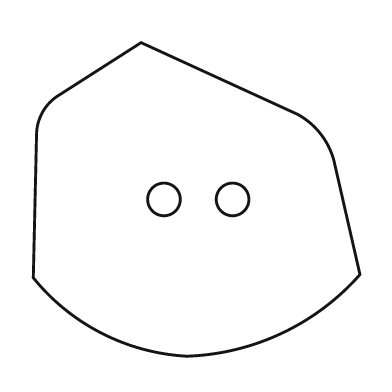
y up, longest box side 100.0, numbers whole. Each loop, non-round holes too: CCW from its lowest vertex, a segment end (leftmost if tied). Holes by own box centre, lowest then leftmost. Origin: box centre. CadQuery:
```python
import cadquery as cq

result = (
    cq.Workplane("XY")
    .moveTo(-3.0, -48.0)
    .threePointArc((26.0, -41.0), (50.0, -23.0))
    .lineTo(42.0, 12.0)
    .threePointArc((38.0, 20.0), (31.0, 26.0))
    .lineTo(-17.0, 48.0)
    .lineTo(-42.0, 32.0)
    .threePointArc((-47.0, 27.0), (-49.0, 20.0))
    .lineTo(-50.0, -24.0)
    .threePointArc((-29.0, -41.0), (-3.0, -48.0))
    .close()
    .moveTo(-10.0, 0.0)
    .circle(5.0)
    .moveTo(11.0, 0.0)
    .circle(5.0)
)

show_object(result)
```